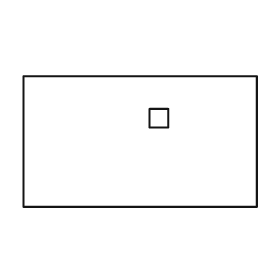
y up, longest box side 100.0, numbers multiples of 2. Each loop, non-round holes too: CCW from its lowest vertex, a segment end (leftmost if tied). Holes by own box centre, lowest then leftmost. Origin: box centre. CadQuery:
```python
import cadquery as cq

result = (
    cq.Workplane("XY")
    .moveTo(-50.0, -28.0)
    .lineTo(50.0, -28.0)
    .lineTo(50.0, 28.0)
    .lineTo(-50.0, 28.0)
    .close()
    .moveTo(4.0, 6.0)
    .lineTo(12.0, 6.0)
    .lineTo(12.0, 14.0)
    .lineTo(4.0, 14.0)
    .close()
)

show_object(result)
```